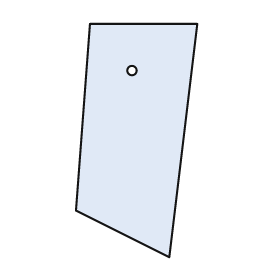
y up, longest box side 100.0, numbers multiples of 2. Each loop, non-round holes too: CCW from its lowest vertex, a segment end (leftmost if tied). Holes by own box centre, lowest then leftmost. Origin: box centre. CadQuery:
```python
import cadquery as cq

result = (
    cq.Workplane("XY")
    .moveTo(14.0, -50.0)
    .lineTo(26.0, 50.0)
    .lineTo(-20.0, 50.0)
    .lineTo(-26.0, -30.0)
    .close()
    .moveTo(-2.0, 30.0)
    .circle(2.0)
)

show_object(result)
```